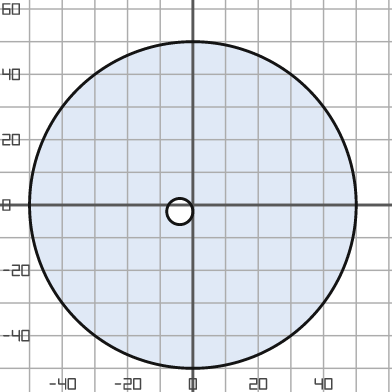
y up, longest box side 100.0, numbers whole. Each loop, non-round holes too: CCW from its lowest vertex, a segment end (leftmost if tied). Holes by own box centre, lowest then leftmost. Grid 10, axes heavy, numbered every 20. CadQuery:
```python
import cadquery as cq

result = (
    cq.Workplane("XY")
    .moveTo(0.0, 0.0)
    .circle(50.0)
    .moveTo(-4.0, -2.0)
    .circle(4.0)
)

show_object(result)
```